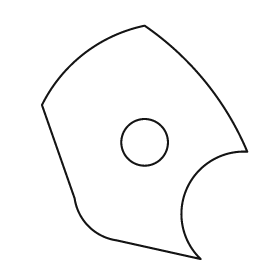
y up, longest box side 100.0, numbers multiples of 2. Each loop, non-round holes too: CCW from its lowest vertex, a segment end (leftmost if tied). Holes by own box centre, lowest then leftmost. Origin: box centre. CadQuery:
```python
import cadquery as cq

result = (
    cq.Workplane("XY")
    .moveTo(24.0, -50.0)
    .threePointArc((18.0, -20.0), (44.0, -4.0))
    .threePointArc((26.0, 26.0), (0.0, 50.0))
    .threePointArc((-26.0, 38.0), (-44.0, 16.0))
    .lineTo(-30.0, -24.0)
    .threePointArc((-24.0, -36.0), (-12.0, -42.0))
    .close()
    .moveTo(0.0, 0.0)
    .circle(10.0)
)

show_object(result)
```